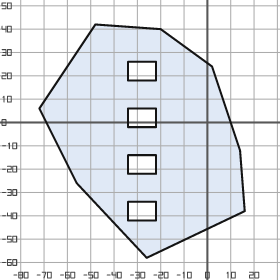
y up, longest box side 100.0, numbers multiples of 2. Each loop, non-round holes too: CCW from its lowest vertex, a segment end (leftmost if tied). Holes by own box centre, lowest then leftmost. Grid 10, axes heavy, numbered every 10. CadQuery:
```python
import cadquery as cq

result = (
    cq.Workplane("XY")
    .moveTo(-26.0, -58.0)
    .lineTo(16.0, -38.0)
    .lineTo(14.0, -12.0)
    .lineTo(2.0, 24.0)
    .lineTo(-20.0, 40.0)
    .lineTo(-48.0, 42.0)
    .lineTo(-72.0, 6.0)
    .lineTo(-56.0, -26.0)
    .close()
    .moveTo(-34.0, -42.0)
    .lineTo(-22.0, -42.0)
    .lineTo(-22.0, -34.0)
    .lineTo(-34.0, -34.0)
    .close()
    .moveTo(-34.0, -22.0)
    .lineTo(-22.0, -22.0)
    .lineTo(-22.0, -14.0)
    .lineTo(-34.0, -14.0)
    .close()
    .moveTo(-34.0, -2.0)
    .lineTo(-22.0, -2.0)
    .lineTo(-22.0, 6.0)
    .lineTo(-34.0, 6.0)
    .close()
    .moveTo(-34.0, 18.0)
    .lineTo(-22.0, 18.0)
    .lineTo(-22.0, 26.0)
    .lineTo(-34.0, 26.0)
    .close()
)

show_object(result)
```